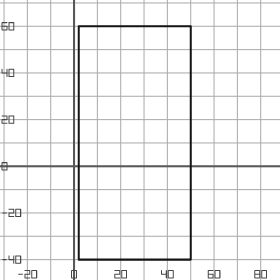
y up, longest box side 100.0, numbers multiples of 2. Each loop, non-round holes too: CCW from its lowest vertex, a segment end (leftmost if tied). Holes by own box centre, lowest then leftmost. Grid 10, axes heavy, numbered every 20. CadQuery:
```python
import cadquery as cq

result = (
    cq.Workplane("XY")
    .moveTo(2.0, -40.0)
    .lineTo(50.0, -40.0)
    .lineTo(50.0, 60.0)
    .lineTo(2.0, 60.0)
    .close()
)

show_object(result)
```